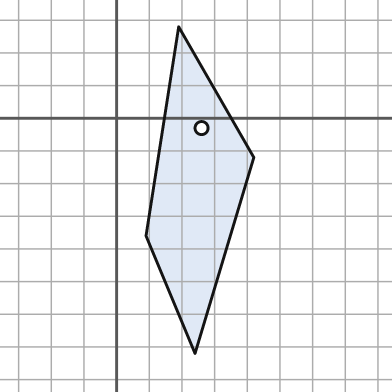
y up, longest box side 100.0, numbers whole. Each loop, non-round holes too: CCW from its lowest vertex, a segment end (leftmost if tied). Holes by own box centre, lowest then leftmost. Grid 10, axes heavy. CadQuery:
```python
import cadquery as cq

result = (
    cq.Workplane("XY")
    .moveTo(24.0, -72.0)
    .lineTo(42.0, -12.0)
    .lineTo(19.0, 28.0)
    .lineTo(9.0, -36.0)
    .close()
    .moveTo(26.0, -3.0)
    .circle(2.0)
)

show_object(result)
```